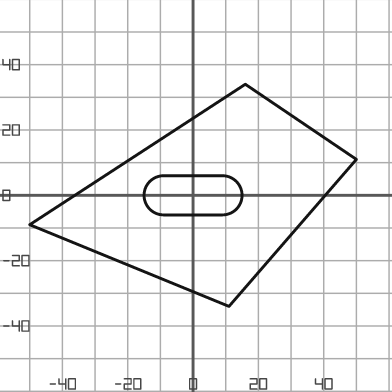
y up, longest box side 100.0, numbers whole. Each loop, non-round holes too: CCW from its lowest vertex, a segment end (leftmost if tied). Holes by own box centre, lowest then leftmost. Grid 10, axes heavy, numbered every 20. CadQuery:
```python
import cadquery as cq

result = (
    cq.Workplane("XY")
    .moveTo(11.0, -34.0)
    .lineTo(50.0, 11.0)
    .lineTo(16.0, 34.0)
    .lineTo(-50.0, -9.0)
    .close()
    .moveTo(-9.0, -6.0)
    .lineTo(9.0, -6.0)
    .threePointArc((15.0, 0.0), (9.0, 6.0))
    .lineTo(-9.0, 6.0)
    .threePointArc((-15.0, 0.0), (-9.0, -6.0))
    .close()
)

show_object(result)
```